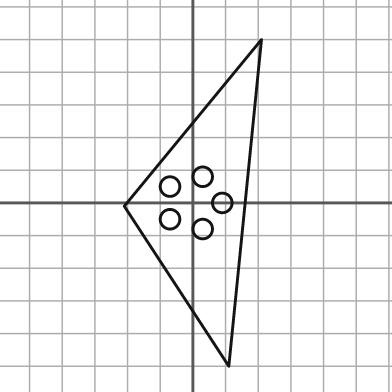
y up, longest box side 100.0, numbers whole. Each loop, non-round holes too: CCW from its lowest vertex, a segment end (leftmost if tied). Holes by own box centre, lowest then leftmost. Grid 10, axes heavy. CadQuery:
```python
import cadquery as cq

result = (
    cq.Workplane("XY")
    .moveTo(11.0, -50.0)
    .lineTo(21.0, 50.0)
    .lineTo(-21.0, -1.0)
    .close()
    .moveTo(3.0, -8.0)
    .circle(3.0)
    .moveTo(-7.0, -5.0)
    .circle(3.0)
    .moveTo(9.0, 0.0)
    .circle(3.0)
    .moveTo(-7.0, 5.0)
    .circle(3.0)
    .moveTo(3.0, 8.0)
    .circle(3.0)
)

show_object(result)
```